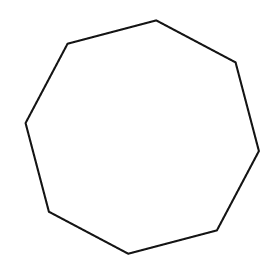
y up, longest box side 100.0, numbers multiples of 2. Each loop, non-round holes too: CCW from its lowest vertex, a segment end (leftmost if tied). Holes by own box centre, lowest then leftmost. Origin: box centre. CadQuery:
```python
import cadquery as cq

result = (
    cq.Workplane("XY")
    .moveTo(-6.0, -50.0)
    .lineTo(32.0, -40.0)
    .lineTo(50.0, -6.0)
    .lineTo(40.0, 32.0)
    .lineTo(6.0, 50.0)
    .lineTo(-32.0, 40.0)
    .lineTo(-50.0, 6.0)
    .lineTo(-40.0, -32.0)
    .close()
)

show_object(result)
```